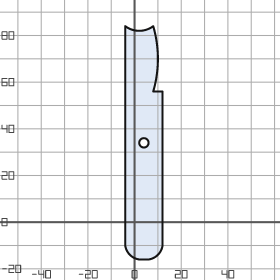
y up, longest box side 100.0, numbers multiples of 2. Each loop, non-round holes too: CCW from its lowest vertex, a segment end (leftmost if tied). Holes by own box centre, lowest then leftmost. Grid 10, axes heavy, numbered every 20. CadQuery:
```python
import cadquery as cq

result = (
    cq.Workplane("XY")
    .moveTo(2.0, -16.0)
    .lineTo(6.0, -16.0)
    .threePointArc((10.0, -14.0), (12.0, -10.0))
    .lineTo(12.0, 56.0)
    .lineTo(8.0, 56.0)
    .threePointArc((10.0, 70.0), (8.0, 84.0))
    .threePointArc((2.0, 82.0), (-4.0, 84.0))
    .lineTo(-4.0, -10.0)
    .threePointArc((-2.0, -14.0), (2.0, -16.0))
    .close()
    .moveTo(4.0, 34.0)
    .circle(2.0)
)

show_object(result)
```